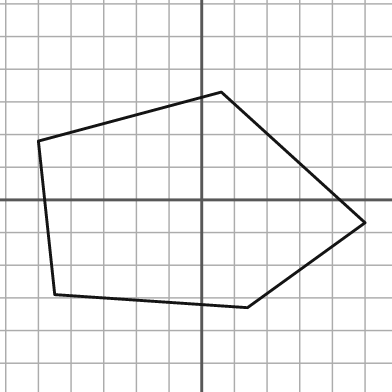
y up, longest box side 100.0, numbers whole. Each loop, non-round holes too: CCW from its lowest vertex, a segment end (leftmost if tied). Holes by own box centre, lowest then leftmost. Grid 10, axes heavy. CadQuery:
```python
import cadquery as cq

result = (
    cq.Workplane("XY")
    .moveTo(14.0, -33.0)
    .lineTo(50.0, -7.0)
    .lineTo(6.0, 33.0)
    .lineTo(-50.0, 18.0)
    .lineTo(-45.0, -29.0)
    .close()
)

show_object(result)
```